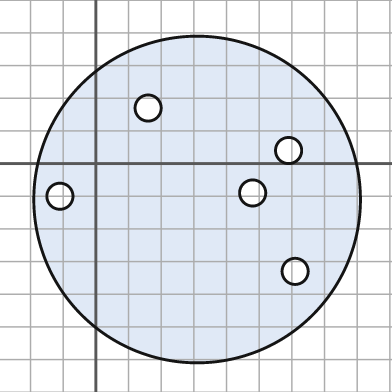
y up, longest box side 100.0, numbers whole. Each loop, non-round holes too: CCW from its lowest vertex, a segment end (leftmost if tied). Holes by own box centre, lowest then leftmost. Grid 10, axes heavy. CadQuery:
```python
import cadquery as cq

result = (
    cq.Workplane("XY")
    .moveTo(31.0, -11.0)
    .circle(50.0)
    .moveTo(61.0, -33.0)
    .circle(4.0)
    .moveTo(-11.0, -10.0)
    .circle(4.0)
    .moveTo(48.0, -9.0)
    .circle(4.0)
    .moveTo(59.0, 4.0)
    .circle(4.0)
    .moveTo(16.0, 17.0)
    .circle(4.0)
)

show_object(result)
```